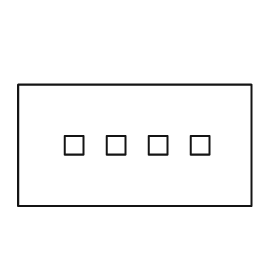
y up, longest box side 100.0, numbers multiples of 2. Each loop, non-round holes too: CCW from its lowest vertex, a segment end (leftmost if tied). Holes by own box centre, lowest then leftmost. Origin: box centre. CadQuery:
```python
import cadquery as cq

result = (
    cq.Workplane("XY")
    .moveTo(-50.0, -26.0)
    .lineTo(50.0, -26.0)
    .lineTo(50.0, 26.0)
    .lineTo(-50.0, 26.0)
    .close()
    .moveTo(-30.0, -4.0)
    .lineTo(-22.0, -4.0)
    .lineTo(-22.0, 4.0)
    .lineTo(-30.0, 4.0)
    .close()
    .moveTo(-12.0, -4.0)
    .lineTo(-4.0, -4.0)
    .lineTo(-4.0, 4.0)
    .lineTo(-12.0, 4.0)
    .close()
    .moveTo(6.0, -4.0)
    .lineTo(14.0, -4.0)
    .lineTo(14.0, 4.0)
    .lineTo(6.0, 4.0)
    .close()
    .moveTo(24.0, -4.0)
    .lineTo(32.0, -4.0)
    .lineTo(32.0, 4.0)
    .lineTo(24.0, 4.0)
    .close()
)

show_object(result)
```